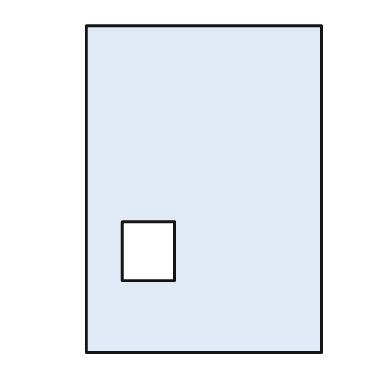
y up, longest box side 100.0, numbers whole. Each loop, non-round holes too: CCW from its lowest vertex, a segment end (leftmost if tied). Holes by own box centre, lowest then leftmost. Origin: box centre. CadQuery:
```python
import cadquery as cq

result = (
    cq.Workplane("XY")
    .moveTo(-36.0, -50.0)
    .lineTo(36.0, -50.0)
    .lineTo(36.0, 50.0)
    .lineTo(-36.0, 50.0)
    .close()
    .moveTo(-25.0, -28.0)
    .lineTo(-9.0, -28.0)
    .lineTo(-9.0, -10.0)
    .lineTo(-25.0, -10.0)
    .close()
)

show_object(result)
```